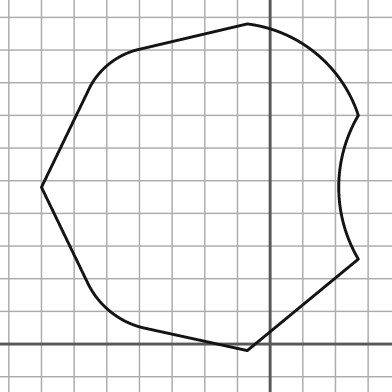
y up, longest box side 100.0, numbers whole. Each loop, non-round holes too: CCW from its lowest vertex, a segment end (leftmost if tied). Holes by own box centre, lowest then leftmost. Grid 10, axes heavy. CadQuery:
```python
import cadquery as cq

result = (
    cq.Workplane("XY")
    .moveTo(-7.0, -2.0)
    .lineTo(27.0, 26.0)
    .threePointArc((21.0, 48.0), (27.0, 70.0))
    .threePointArc((14.0, 89.0), (-7.0, 98.0))
    .lineTo(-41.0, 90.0)
    .threePointArc((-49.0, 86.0), (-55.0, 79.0))
    .lineTo(-70.0, 48.0)
    .lineTo(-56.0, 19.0)
    .threePointArc((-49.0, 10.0), (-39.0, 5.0))
    .close()
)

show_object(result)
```